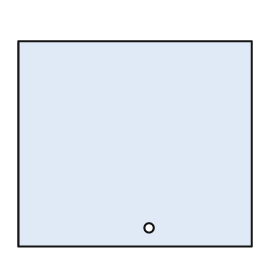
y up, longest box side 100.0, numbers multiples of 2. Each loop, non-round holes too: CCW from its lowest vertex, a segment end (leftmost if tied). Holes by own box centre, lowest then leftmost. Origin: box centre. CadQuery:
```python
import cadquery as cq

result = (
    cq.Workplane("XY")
    .moveTo(-50.0, -44.0)
    .lineTo(50.0, -44.0)
    .lineTo(50.0, 44.0)
    .lineTo(-50.0, 44.0)
    .close()
    .moveTo(6.0, -36.0)
    .circle(2.0)
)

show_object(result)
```